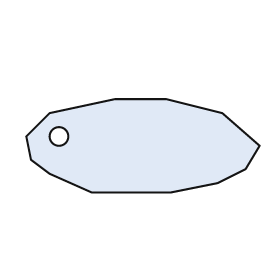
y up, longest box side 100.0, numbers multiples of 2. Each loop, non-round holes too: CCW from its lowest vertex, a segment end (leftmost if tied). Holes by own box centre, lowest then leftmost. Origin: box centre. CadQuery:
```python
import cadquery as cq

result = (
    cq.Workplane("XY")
    .moveTo(-22.0, -20.0)
    .lineTo(12.0, -20.0)
    .lineTo(32.0, -16.0)
    .lineTo(44.0, -10.0)
    .lineTo(50.0, 0.0)
    .lineTo(34.0, 14.0)
    .lineTo(10.0, 20.0)
    .lineTo(-12.0, 20.0)
    .lineTo(-40.0, 14.0)
    .lineTo(-50.0, 4.0)
    .lineTo(-48.0, -6.0)
    .lineTo(-40.0, -12.0)
    .close()
    .moveTo(-36.0, 4.0)
    .circle(4.0)
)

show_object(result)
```